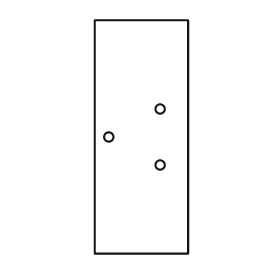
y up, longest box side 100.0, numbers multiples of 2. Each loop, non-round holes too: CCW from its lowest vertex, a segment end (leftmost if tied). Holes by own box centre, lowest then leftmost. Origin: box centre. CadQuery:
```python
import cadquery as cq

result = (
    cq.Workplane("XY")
    .moveTo(-20.0, -50.0)
    .lineTo(20.0, -50.0)
    .lineTo(20.0, 50.0)
    .lineTo(-20.0, 50.0)
    .close()
    .moveTo(8.0, -12.0)
    .circle(2.0)
    .moveTo(-14.0, 0.0)
    .circle(2.0)
    .moveTo(8.0, 12.0)
    .circle(2.0)
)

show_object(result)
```